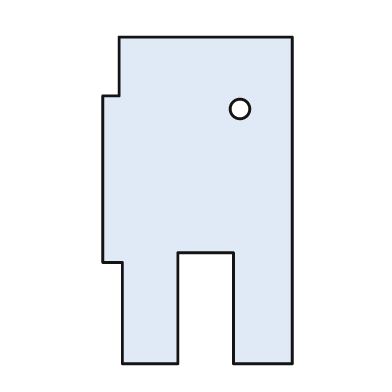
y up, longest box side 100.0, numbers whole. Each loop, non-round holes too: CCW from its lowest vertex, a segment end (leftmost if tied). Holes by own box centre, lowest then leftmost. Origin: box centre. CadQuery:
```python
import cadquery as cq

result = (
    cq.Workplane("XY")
    .moveTo(-23.0, -50.0)
    .lineTo(-6.0, -50.0)
    .lineTo(-6.0, -16.0)
    .lineTo(11.0, -16.0)
    .lineTo(11.0, -50.0)
    .lineTo(29.0, -50.0)
    .lineTo(29.0, 50.0)
    .lineTo(-24.0, 50.0)
    .lineTo(-24.0, 32.0)
    .lineTo(-29.0, 32.0)
    .lineTo(-29.0, -19.0)
    .lineTo(-23.0, -19.0)
    .close()
    .moveTo(13.0, 28.0)
    .circle(3.0)
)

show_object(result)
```